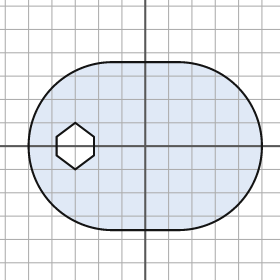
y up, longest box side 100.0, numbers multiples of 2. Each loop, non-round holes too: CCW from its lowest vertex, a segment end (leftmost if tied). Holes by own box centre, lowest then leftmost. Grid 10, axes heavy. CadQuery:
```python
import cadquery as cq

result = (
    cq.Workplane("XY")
    .moveTo(-14.0, -36.0)
    .lineTo(14.0, -36.0)
    .threePointArc((50.0, 0.0), (14.0, 36.0))
    .lineTo(-14.0, 36.0)
    .threePointArc((-50.0, 0.0), (-14.0, -36.0))
    .close()
    .moveTo(-30.0, -10.0)
    .lineTo(-22.0, -4.0)
    .lineTo(-22.0, 4.0)
    .lineTo(-30.0, 10.0)
    .lineTo(-38.0, 4.0)
    .lineTo(-38.0, -4.0)
    .close()
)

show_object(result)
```